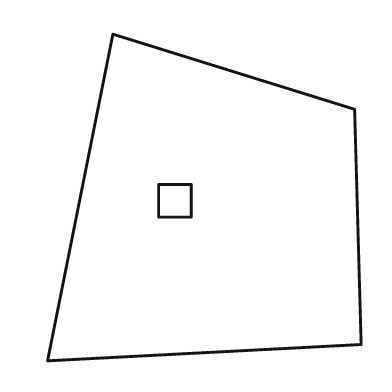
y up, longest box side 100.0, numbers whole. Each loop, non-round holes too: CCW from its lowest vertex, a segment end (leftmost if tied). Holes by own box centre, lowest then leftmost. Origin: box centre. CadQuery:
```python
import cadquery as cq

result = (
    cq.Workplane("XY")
    .moveTo(-48.0, -50.0)
    .lineTo(48.0, -45.0)
    .lineTo(46.0, 27.0)
    .lineTo(-28.0, 50.0)
    .close()
    .moveTo(-14.0, -6.0)
    .lineTo(-4.0, -6.0)
    .lineTo(-4.0, 4.0)
    .lineTo(-14.0, 4.0)
    .close()
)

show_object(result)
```